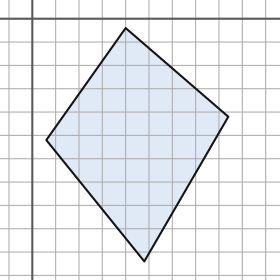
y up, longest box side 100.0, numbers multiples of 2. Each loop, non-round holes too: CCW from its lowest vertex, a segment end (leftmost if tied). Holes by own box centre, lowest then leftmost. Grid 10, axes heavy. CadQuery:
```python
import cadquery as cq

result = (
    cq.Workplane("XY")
    .moveTo(48.0, -104.0)
    .lineTo(84.0, -42.0)
    .lineTo(40.0, -4.0)
    .lineTo(6.0, -52.0)
    .close()
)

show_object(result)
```